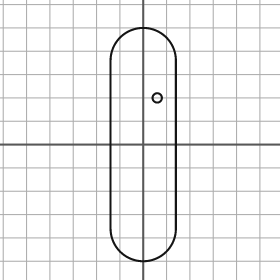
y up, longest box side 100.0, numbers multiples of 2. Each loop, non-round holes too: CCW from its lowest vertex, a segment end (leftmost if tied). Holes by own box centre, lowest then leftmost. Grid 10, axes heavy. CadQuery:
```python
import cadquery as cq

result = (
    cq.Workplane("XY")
    .moveTo(-14.0, -36.0)
    .threePointArc((0.0, -50.0), (14.0, -36.0))
    .lineTo(14.0, 36.0)
    .threePointArc((0.0, 50.0), (-14.0, 36.0))
    .close()
    .moveTo(6.0, 20.0)
    .circle(2.0)
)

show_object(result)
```